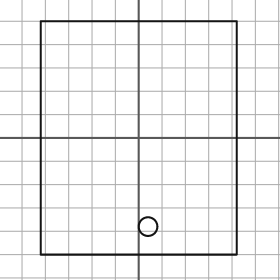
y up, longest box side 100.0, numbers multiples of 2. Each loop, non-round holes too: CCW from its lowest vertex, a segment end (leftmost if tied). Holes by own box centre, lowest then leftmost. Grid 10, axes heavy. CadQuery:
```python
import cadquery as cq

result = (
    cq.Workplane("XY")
    .moveTo(-42.0, -50.0)
    .lineTo(42.0, -50.0)
    .lineTo(42.0, 50.0)
    .lineTo(-42.0, 50.0)
    .close()
    .moveTo(4.0, -38.0)
    .circle(4.0)
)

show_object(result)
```